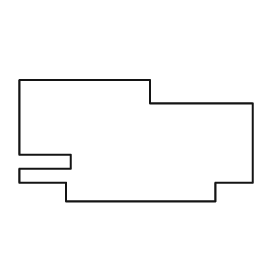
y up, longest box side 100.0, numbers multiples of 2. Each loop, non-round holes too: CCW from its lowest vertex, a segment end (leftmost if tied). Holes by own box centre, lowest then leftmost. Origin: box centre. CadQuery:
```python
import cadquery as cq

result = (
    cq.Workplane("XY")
    .moveTo(-30.0, -26.0)
    .lineTo(34.0, -26.0)
    .lineTo(34.0, -18.0)
    .lineTo(50.0, -18.0)
    .lineTo(50.0, 16.0)
    .lineTo(6.0, 16.0)
    .lineTo(6.0, 26.0)
    .lineTo(-50.0, 26.0)
    .lineTo(-50.0, -6.0)
    .lineTo(-28.0, -6.0)
    .lineTo(-28.0, -12.0)
    .lineTo(-50.0, -12.0)
    .lineTo(-50.0, -18.0)
    .lineTo(-30.0, -18.0)
    .close()
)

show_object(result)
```